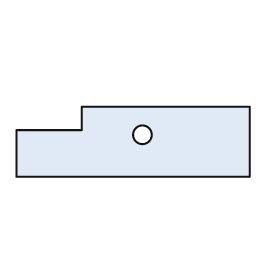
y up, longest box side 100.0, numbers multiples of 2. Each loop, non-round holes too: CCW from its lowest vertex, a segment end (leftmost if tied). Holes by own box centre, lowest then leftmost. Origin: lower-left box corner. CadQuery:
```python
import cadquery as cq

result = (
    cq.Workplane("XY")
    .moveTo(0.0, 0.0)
    .lineTo(100.0, 0.0)
    .lineTo(100.0, 30.0)
    .lineTo(28.0, 30.0)
    .lineTo(28.0, 20.0)
    .lineTo(0.0, 20.0)
    .close()
    .moveTo(54.0, 18.0)
    .circle(4.0)
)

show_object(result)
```